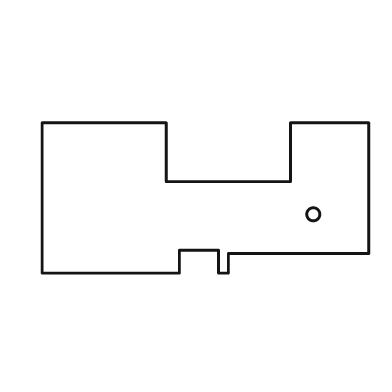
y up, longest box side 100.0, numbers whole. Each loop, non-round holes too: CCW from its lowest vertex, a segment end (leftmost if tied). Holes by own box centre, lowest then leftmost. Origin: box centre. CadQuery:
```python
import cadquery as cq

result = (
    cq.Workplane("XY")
    .moveTo(-50.0, -23.0)
    .lineTo(-8.0, -23.0)
    .lineTo(-8.0, -16.0)
    .lineTo(4.0, -16.0)
    .lineTo(4.0, -23.0)
    .lineTo(7.0, -23.0)
    .lineTo(7.0, -17.0)
    .lineTo(50.0, -17.0)
    .lineTo(50.0, 23.0)
    .lineTo(26.0, 23.0)
    .lineTo(26.0, 5.0)
    .lineTo(-12.0, 5.0)
    .lineTo(-12.0, 23.0)
    .lineTo(-50.0, 23.0)
    .close()
    .moveTo(33.0, -5.0)
    .circle(2.0)
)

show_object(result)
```